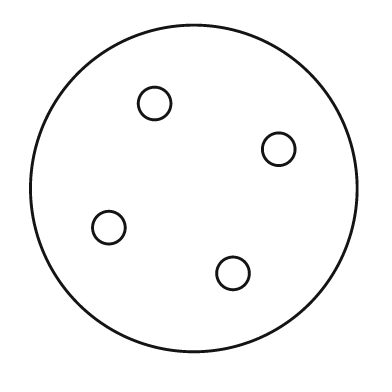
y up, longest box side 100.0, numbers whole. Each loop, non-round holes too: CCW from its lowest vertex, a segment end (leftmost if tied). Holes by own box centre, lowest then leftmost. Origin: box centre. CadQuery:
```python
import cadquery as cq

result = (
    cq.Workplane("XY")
    .moveTo(0.0, 0.0)
    .circle(50.0)
    .moveTo(12.0, -26.0)
    .circle(5.0)
    .moveTo(-26.0, -12.0)
    .circle(5.0)
    .moveTo(26.0, 12.0)
    .circle(5.0)
    .moveTo(-12.0, 26.0)
    .circle(5.0)
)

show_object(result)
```